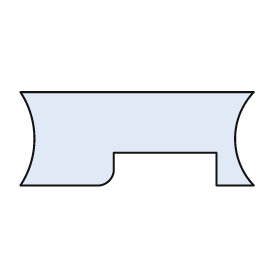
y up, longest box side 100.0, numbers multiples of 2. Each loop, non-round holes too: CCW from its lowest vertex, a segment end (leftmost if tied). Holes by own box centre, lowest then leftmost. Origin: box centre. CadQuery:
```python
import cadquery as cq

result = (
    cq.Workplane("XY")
    .moveTo(-50.0, -20.0)
    .lineTo(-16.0, -20.0)
    .threePointArc((-12.0, -18.0), (-10.0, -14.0))
    .lineTo(-10.0, -6.0)
    .lineTo(34.0, -6.0)
    .lineTo(34.0, -20.0)
    .lineTo(50.0, -20.0)
    .threePointArc((42.0, 0.0), (50.0, 20.0))
    .lineTo(-50.0, 20.0)
    .threePointArc((-44.0, 0.0), (-50.0, -20.0))
    .close()
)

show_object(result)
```